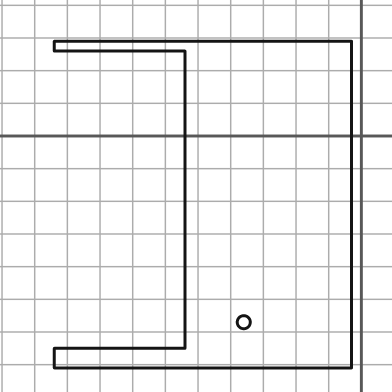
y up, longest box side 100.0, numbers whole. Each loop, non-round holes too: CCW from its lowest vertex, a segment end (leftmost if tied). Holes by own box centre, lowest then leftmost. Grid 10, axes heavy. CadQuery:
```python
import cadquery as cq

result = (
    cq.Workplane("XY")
    .moveTo(-94.0, -71.0)
    .lineTo(-3.0, -71.0)
    .lineTo(-3.0, 29.0)
    .lineTo(-94.0, 29.0)
    .lineTo(-94.0, 26.0)
    .lineTo(-54.0, 26.0)
    .lineTo(-54.0, -65.0)
    .lineTo(-94.0, -65.0)
    .close()
    .moveTo(-36.0, -57.0)
    .circle(2.0)
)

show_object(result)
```